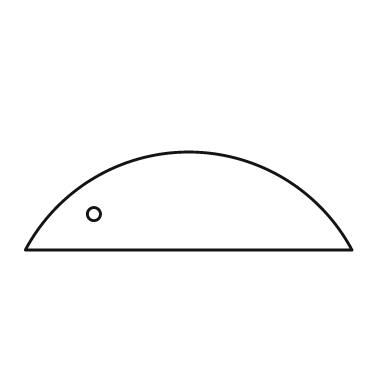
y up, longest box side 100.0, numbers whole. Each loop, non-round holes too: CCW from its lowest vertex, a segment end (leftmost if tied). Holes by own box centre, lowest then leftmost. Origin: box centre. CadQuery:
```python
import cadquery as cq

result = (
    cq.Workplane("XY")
    .moveTo(-50.0, -15.0)
    .lineTo(50.0, -15.0)
    .threePointArc((0.0, 15.0), (-50.0, -15.0))
    .close()
    .moveTo(-29.0, -4.0)
    .circle(2.0)
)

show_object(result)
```